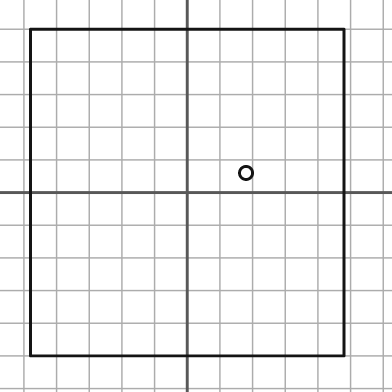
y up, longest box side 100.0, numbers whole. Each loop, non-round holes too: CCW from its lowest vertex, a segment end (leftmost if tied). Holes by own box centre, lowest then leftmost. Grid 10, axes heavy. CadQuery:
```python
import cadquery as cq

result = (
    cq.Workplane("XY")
    .moveTo(-48.0, -50.0)
    .lineTo(48.0, -50.0)
    .lineTo(48.0, 50.0)
    .lineTo(-48.0, 50.0)
    .close()
    .moveTo(18.0, 6.0)
    .circle(2.0)
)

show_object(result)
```